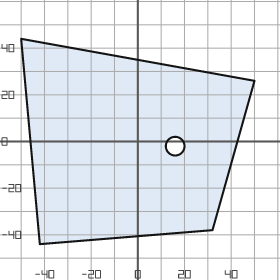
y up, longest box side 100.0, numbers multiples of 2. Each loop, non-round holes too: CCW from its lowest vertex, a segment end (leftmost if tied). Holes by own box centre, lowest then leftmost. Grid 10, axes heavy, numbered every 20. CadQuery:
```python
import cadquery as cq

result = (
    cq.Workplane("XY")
    .moveTo(-42.0, -44.0)
    .lineTo(32.0, -38.0)
    .lineTo(50.0, 26.0)
    .lineTo(-50.0, 44.0)
    .close()
    .moveTo(16.0, -2.0)
    .circle(4.0)
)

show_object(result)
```